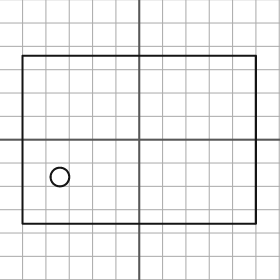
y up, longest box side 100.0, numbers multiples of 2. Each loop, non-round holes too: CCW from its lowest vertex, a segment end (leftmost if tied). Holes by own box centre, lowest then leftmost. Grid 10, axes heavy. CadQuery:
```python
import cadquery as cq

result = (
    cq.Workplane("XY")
    .moveTo(-50.0, -36.0)
    .lineTo(50.0, -36.0)
    .lineTo(50.0, 36.0)
    .lineTo(-50.0, 36.0)
    .close()
    .moveTo(-34.0, -16.0)
    .circle(4.0)
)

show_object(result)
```